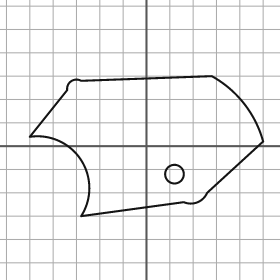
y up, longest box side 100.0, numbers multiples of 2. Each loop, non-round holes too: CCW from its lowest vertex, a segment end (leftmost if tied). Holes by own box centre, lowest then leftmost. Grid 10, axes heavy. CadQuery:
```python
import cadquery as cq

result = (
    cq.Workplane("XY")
    .moveTo(-28.0, -30.0)
    .lineTo(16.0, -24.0)
    .threePointArc((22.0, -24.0), (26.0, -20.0))
    .lineTo(50.0, 2.0)
    .threePointArc((42.0, 18.0), (28.0, 30.0))
    .lineTo(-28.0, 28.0)
    .threePointArc((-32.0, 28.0), (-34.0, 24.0))
    .lineTo(-50.0, 4.0)
    .threePointArc((-28.0, -6.0), (-28.0, -30.0))
    .close()
    .moveTo(12.0, -12.0)
    .circle(4.0)
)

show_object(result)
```